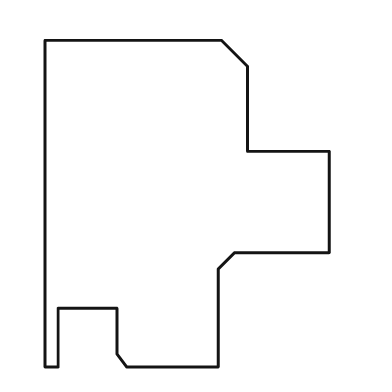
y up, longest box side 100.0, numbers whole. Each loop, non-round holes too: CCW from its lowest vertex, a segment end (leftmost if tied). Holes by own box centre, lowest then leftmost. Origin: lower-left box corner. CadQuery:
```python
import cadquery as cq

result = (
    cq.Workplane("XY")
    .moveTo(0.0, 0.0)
    .lineTo(4.0, 0.0)
    .lineTo(4.0, 18.0)
    .lineTo(22.0, 18.0)
    .lineTo(22.0, 4.0)
    .lineTo(25.0, 0.0)
    .lineTo(53.0, 0.0)
    .lineTo(53.0, 30.0)
    .lineTo(58.0, 35.0)
    .lineTo(87.0, 35.0)
    .lineTo(87.0, 66.0)
    .lineTo(62.0, 66.0)
    .lineTo(62.0, 92.0)
    .lineTo(54.0, 100.0)
    .lineTo(0.0, 100.0)
    .close()
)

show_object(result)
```